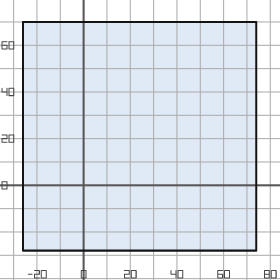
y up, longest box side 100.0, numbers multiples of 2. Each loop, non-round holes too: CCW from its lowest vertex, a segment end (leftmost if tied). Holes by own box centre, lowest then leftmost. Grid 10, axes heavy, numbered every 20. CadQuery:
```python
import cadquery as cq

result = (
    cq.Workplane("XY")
    .moveTo(-26.0, -28.0)
    .lineTo(74.0, -28.0)
    .lineTo(74.0, 70.0)
    .lineTo(-26.0, 70.0)
    .close()
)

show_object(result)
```